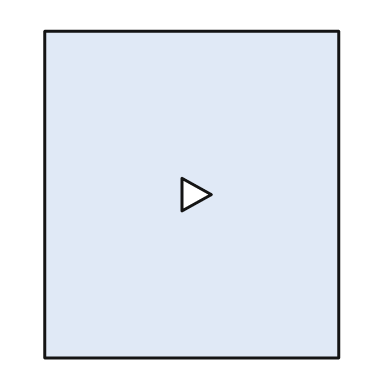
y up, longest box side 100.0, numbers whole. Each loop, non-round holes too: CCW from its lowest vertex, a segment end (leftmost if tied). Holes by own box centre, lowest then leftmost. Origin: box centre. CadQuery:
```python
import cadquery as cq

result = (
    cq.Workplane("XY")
    .moveTo(-45.0, -50.0)
    .lineTo(45.0, -50.0)
    .lineTo(45.0, 50.0)
    .lineTo(-45.0, 50.0)
    .close()
    .moveTo(-3.0, -5.0)
    .lineTo(6.0, 0.0)
    .lineTo(-3.0, 5.0)
    .close()
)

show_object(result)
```